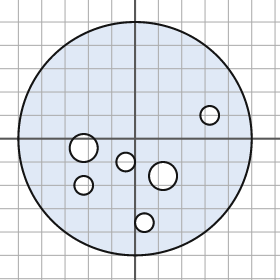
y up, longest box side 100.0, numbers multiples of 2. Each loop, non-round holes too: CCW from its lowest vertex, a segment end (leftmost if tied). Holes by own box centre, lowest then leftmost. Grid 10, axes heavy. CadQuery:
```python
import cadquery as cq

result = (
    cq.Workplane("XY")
    .moveTo(0.0, 0.0)
    .circle(50.0)
    .moveTo(4.0, -36.0)
    .circle(4.0)
    .moveTo(-22.0, -20.0)
    .circle(4.0)
    .moveTo(12.0, -16.0)
    .circle(6.0)
    .moveTo(-4.0, -10.0)
    .circle(4.0)
    .moveTo(-22.0, -4.0)
    .circle(6.0)
    .moveTo(32.0, 10.0)
    .circle(4.0)
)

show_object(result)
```